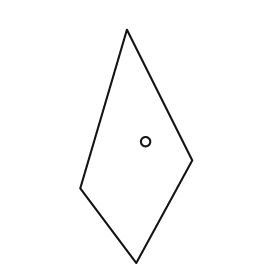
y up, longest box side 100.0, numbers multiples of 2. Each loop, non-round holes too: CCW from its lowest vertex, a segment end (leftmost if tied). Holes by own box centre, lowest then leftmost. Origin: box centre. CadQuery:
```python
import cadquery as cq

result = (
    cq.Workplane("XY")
    .moveTo(0.0, -50.0)
    .lineTo(24.0, -6.0)
    .lineTo(-4.0, 50.0)
    .lineTo(-24.0, -18.0)
    .close()
    .moveTo(4.0, 2.0)
    .circle(2.0)
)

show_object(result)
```